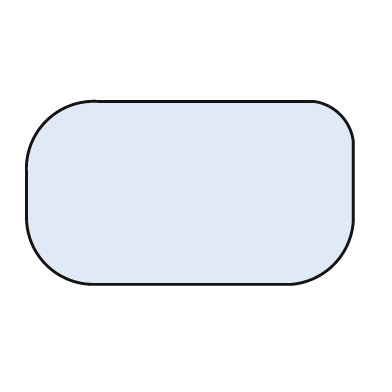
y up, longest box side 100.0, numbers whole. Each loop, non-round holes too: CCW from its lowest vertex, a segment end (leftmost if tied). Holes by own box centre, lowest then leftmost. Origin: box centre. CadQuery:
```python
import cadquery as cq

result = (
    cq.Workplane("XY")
    .moveTo(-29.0, -28.0)
    .lineTo(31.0, -28.0)
    .threePointArc((44.0, -22.0), (50.0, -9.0))
    .lineTo(50.0, 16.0)
    .threePointArc((46.0, 24.0), (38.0, 28.0))
    .lineTo(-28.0, 28.0)
    .threePointArc((-44.0, 22.0), (-50.0, 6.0))
    .lineTo(-50.0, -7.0)
    .threePointArc((-44.0, -22.0), (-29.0, -28.0))
    .close()
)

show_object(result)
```